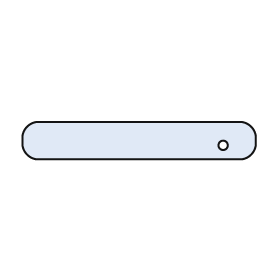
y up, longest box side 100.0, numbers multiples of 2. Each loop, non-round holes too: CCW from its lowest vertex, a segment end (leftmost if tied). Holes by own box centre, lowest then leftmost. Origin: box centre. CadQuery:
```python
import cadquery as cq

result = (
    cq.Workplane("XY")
    .moveTo(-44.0, -8.0)
    .lineTo(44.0, -8.0)
    .threePointArc((48.0, -6.0), (50.0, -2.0))
    .lineTo(50.0, 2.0)
    .threePointArc((48.0, 6.0), (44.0, 8.0))
    .lineTo(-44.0, 8.0)
    .threePointArc((-48.0, 6.0), (-50.0, 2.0))
    .lineTo(-50.0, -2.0)
    .threePointArc((-48.0, -6.0), (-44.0, -8.0))
    .close()
    .moveTo(36.0, -2.0)
    .circle(2.0)
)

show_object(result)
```